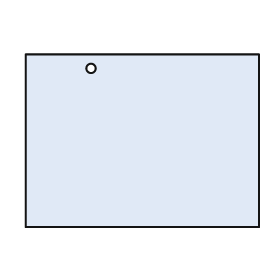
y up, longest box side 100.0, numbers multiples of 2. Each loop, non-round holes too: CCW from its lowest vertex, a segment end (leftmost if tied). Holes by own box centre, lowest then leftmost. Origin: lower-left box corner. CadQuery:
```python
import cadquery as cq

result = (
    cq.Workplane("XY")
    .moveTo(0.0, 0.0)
    .lineTo(100.0, 0.0)
    .lineTo(100.0, 74.0)
    .lineTo(0.0, 74.0)
    .close()
    .moveTo(28.0, 68.0)
    .circle(2.0)
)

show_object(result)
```